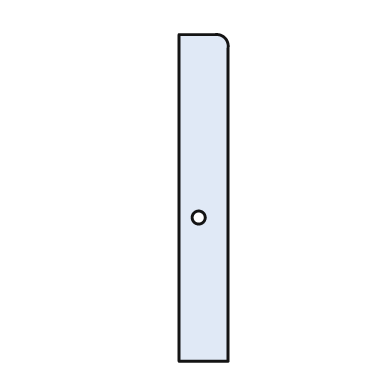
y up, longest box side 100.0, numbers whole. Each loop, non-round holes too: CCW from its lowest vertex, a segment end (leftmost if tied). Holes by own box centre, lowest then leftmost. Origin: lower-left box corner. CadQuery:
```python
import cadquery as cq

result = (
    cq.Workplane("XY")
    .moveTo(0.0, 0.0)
    .lineTo(15.0, 0.0)
    .lineTo(15.0, 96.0)
    .threePointArc((14.0, 99.0), (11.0, 100.0))
    .lineTo(0.0, 100.0)
    .close()
    .moveTo(6.0, 44.0)
    .circle(2.0)
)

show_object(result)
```